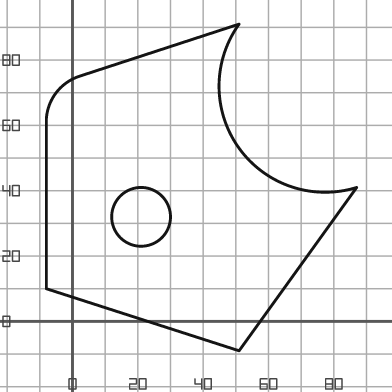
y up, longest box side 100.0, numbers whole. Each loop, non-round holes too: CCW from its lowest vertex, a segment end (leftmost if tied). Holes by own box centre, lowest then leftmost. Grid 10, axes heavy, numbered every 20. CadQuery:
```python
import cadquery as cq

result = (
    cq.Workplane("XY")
    .moveTo(51.0, -9.0)
    .lineTo(87.0, 41.0)
    .threePointArc((51.0, 53.0), (51.0, 91.0))
    .lineTo(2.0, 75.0)
    .threePointArc((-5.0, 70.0), (-8.0, 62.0))
    .lineTo(-8.0, 10.0)
    .close()
    .moveTo(21.0, 32.0)
    .circle(9.0)
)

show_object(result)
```